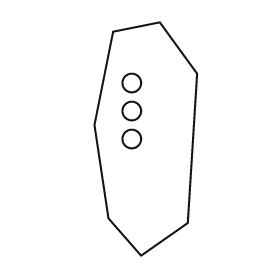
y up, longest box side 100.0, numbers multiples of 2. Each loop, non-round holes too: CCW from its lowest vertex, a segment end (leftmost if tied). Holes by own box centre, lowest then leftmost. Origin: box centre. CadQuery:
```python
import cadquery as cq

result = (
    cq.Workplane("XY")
    .moveTo(-2.0, -50.0)
    .lineTo(18.0, -36.0)
    .lineTo(22.0, 28.0)
    .lineTo(6.0, 50.0)
    .lineTo(-14.0, 46.0)
    .lineTo(-22.0, 6.0)
    .lineTo(-16.0, -34.0)
    .close()
    .moveTo(-6.0, 0.0)
    .circle(4.0)
    .moveTo(-6.0, 12.0)
    .circle(4.0)
    .moveTo(-6.0, 24.0)
    .circle(4.0)
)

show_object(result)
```